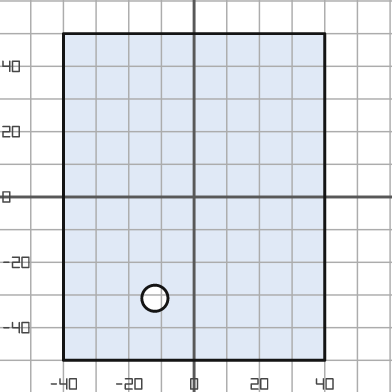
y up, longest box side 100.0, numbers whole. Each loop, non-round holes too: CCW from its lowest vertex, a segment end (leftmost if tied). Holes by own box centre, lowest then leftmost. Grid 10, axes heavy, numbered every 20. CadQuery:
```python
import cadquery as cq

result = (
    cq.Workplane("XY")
    .moveTo(-40.0, -50.0)
    .lineTo(40.0, -50.0)
    .lineTo(40.0, 50.0)
    .lineTo(-40.0, 50.0)
    .close()
    .moveTo(-12.0, -31.0)
    .circle(4.0)
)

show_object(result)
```